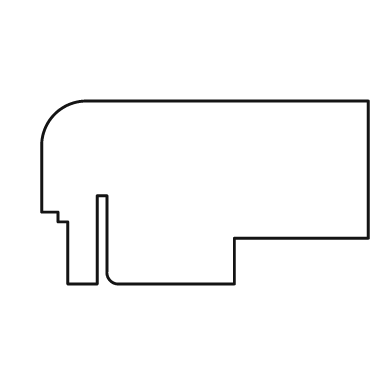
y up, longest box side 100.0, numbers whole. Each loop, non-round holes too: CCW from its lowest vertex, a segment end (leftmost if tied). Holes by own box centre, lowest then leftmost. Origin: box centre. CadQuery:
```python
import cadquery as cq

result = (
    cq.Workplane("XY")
    .moveTo(-42.0, -28.0)
    .lineTo(-33.0, -28.0)
    .lineTo(-33.0, -1.0)
    .lineTo(-30.0, -1.0)
    .lineTo(-30.0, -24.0)
    .threePointArc((-29.0, -27.0), (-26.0, -28.0))
    .lineTo(9.0, -28.0)
    .lineTo(9.0, -14.0)
    .lineTo(50.0, -14.0)
    .lineTo(50.0, 28.0)
    .lineTo(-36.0, 28.0)
    .threePointArc((-46.0, 24.0), (-50.0, 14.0))
    .lineTo(-50.0, -6.0)
    .lineTo(-45.0, -6.0)
    .lineTo(-45.0, -9.0)
    .lineTo(-42.0, -9.0)
    .close()
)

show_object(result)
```